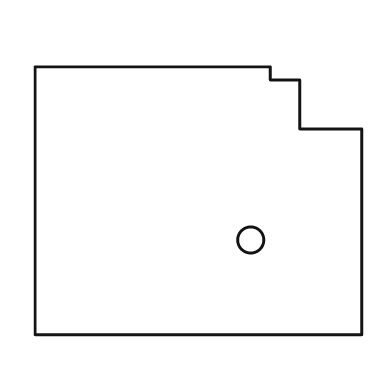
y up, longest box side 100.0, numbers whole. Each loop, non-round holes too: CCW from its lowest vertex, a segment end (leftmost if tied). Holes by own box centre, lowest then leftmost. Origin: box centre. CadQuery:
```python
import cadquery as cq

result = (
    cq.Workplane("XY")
    .moveTo(-50.0, -41.0)
    .lineTo(50.0, -41.0)
    .lineTo(50.0, 22.0)
    .lineTo(31.0, 22.0)
    .lineTo(31.0, 37.0)
    .lineTo(22.0, 37.0)
    .lineTo(22.0, 41.0)
    .lineTo(-50.0, 41.0)
    .close()
    .moveTo(16.0, -12.0)
    .circle(4.0)
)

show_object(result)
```